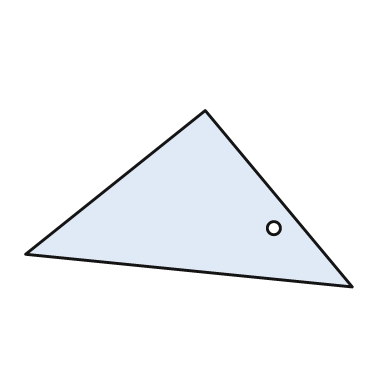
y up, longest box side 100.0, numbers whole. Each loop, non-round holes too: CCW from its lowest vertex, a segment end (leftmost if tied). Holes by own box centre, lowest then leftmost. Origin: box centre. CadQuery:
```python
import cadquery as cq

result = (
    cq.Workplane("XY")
    .moveTo(50.0, -27.0)
    .lineTo(5.0, 27.0)
    .lineTo(-50.0, -17.0)
    .close()
    .moveTo(26.0, -9.0)
    .circle(2.0)
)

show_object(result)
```